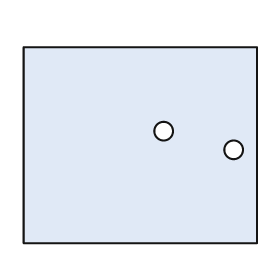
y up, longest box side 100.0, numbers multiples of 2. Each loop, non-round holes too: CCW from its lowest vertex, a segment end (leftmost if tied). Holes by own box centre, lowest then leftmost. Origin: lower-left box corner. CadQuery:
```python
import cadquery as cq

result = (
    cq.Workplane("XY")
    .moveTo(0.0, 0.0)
    .lineTo(100.0, 0.0)
    .lineTo(100.0, 84.0)
    .lineTo(0.0, 84.0)
    .close()
    .moveTo(90.0, 40.0)
    .circle(4.0)
    .moveTo(60.0, 48.0)
    .circle(4.0)
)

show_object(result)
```